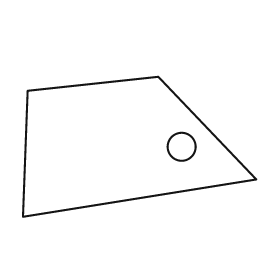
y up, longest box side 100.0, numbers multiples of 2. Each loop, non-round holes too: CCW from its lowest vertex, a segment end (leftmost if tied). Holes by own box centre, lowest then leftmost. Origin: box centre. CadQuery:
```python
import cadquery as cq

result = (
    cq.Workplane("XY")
    .moveTo(-50.0, -30.0)
    .lineTo(50.0, -14.0)
    .lineTo(8.0, 30.0)
    .lineTo(-48.0, 24.0)
    .close()
    .moveTo(18.0, 0.0)
    .circle(6.0)
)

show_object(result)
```